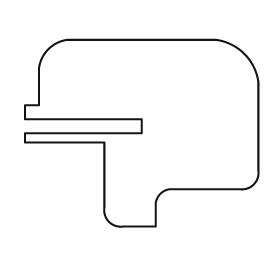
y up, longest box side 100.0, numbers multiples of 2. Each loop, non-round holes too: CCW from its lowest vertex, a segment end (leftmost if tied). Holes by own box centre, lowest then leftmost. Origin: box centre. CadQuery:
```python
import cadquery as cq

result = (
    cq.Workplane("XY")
    .moveTo(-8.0, -40.0)
    .lineTo(6.0, -40.0)
    .lineTo(6.0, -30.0)
    .threePointArc((8.0, -26.0), (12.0, -24.0))
    .lineTo(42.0, -24.0)
    .threePointArc((48.0, -22.0), (50.0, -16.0))
    .lineTo(50.0, 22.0)
    .threePointArc((44.0, 34.0), (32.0, 40.0))
    .lineTo(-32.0, 40.0)
    .threePointArc((-40.0, 36.0), (-44.0, 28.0))
    .lineTo(-44.0, 12.0)
    .lineTo(-50.0, 12.0)
    .lineTo(-50.0, 6.0)
    .lineTo(0.0, 6.0)
    .lineTo(0.0, 0.0)
    .lineTo(-50.0, 0.0)
    .lineTo(-50.0, -4.0)
    .lineTo(-16.0, -4.0)
    .lineTo(-16.0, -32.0)
    .threePointArc((-14.0, -38.0), (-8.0, -40.0))
    .close()
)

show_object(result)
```